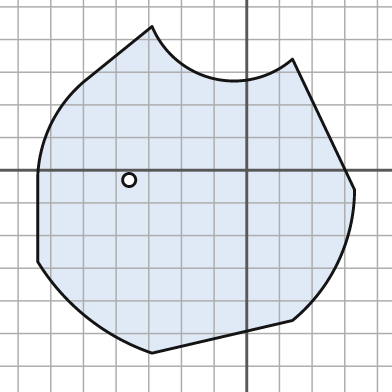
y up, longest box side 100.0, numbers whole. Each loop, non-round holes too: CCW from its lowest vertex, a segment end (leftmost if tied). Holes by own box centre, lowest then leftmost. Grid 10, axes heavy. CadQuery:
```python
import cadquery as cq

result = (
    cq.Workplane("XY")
    .moveTo(-29.0, -56.0)
    .lineTo(14.0, -46.0)
    .threePointArc((28.0, -28.0), (33.0, -6.0))
    .lineTo(14.0, 34.0)
    .threePointArc((-10.0, 28.0), (-29.0, 44.0))
    .lineTo(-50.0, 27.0)
    .threePointArc((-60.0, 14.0), (-64.0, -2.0))
    .lineTo(-64.0, -28.0)
    .threePointArc((-49.0, -45.0), (-29.0, -56.0))
    .close()
    .moveTo(-36.0, -3.0)
    .circle(2.0)
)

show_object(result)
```